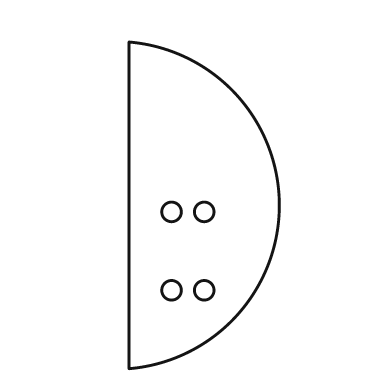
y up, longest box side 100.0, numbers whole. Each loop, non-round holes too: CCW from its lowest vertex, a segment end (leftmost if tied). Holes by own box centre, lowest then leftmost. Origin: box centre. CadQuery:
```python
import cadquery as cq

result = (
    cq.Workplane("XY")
    .moveTo(-23.0, -50.0)
    .threePointArc((23.0, 0.0), (-23.0, 50.0))
    .close()
    .moveTo(-10.0, -26.0)
    .circle(3.0)
    .moveTo(0.0, -26.0)
    .circle(3.0)
    .moveTo(-10.0, -2.0)
    .circle(3.0)
    .moveTo(0.0, -2.0)
    .circle(3.0)
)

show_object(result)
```